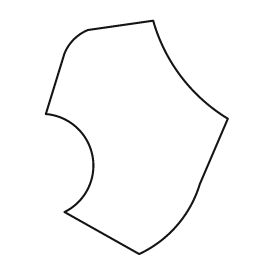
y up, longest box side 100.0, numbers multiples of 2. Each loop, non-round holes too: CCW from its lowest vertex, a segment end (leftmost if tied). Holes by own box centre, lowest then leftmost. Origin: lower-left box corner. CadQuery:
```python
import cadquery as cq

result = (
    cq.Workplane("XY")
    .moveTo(40.0, 0.0)
    .threePointArc((56.0, 12.0), (66.0, 30.0))
    .lineTo(78.0, 58.0)
    .threePointArc((58.0, 76.0), (46.0, 100.0))
    .lineTo(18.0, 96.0)
    .threePointArc((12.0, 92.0), (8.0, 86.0))
    .lineTo(0.0, 60.0)
    .threePointArc((20.0, 42.0), (8.0, 18.0))
    .close()
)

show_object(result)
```